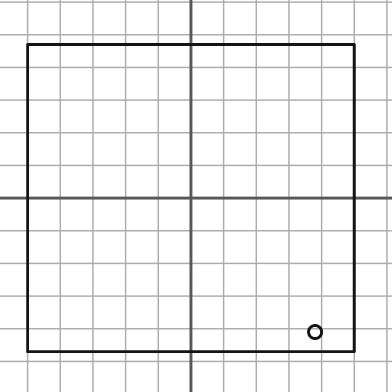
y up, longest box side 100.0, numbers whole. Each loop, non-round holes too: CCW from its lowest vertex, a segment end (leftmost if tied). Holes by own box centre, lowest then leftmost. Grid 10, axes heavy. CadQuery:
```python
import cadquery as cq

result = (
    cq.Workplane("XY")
    .moveTo(-50.0, -47.0)
    .lineTo(50.0, -47.0)
    .lineTo(50.0, 47.0)
    .lineTo(-50.0, 47.0)
    .close()
    .moveTo(38.0, -41.0)
    .circle(2.0)
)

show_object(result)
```